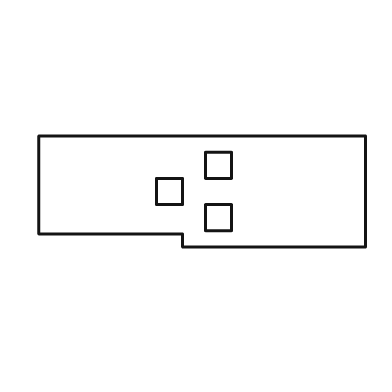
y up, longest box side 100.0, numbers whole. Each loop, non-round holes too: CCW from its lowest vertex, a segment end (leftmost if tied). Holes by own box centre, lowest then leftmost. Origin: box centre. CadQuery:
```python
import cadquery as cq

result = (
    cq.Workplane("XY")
    .moveTo(-6.0, -17.0)
    .lineTo(50.0, -17.0)
    .lineTo(50.0, 17.0)
    .lineTo(-50.0, 17.0)
    .lineTo(-50.0, -13.0)
    .lineTo(-6.0, -13.0)
    .close()
    .moveTo(1.0, -12.0)
    .lineTo(9.0, -12.0)
    .lineTo(9.0, -4.0)
    .lineTo(1.0, -4.0)
    .close()
    .moveTo(-14.0, -4.0)
    .lineTo(-6.0, -4.0)
    .lineTo(-6.0, 4.0)
    .lineTo(-14.0, 4.0)
    .close()
    .moveTo(1.0, 4.0)
    .lineTo(9.0, 4.0)
    .lineTo(9.0, 12.0)
    .lineTo(1.0, 12.0)
    .close()
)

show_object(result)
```